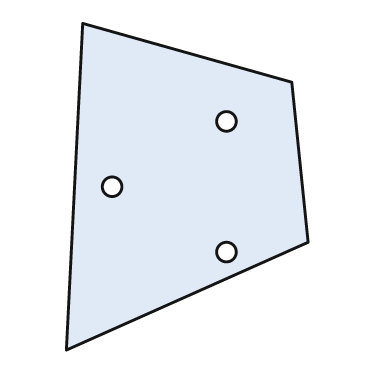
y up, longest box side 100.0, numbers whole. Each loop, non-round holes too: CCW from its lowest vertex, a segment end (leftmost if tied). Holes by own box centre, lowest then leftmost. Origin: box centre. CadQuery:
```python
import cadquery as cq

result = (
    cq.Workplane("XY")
    .moveTo(-37.0, -50.0)
    .lineTo(37.0, -17.0)
    .lineTo(32.0, 32.0)
    .lineTo(-32.0, 50.0)
    .close()
    .moveTo(12.0, -20.0)
    .circle(3.0)
    .moveTo(-23.0, 0.0)
    .circle(3.0)
    .moveTo(12.0, 20.0)
    .circle(3.0)
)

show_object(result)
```